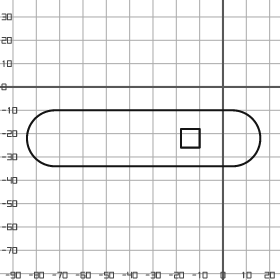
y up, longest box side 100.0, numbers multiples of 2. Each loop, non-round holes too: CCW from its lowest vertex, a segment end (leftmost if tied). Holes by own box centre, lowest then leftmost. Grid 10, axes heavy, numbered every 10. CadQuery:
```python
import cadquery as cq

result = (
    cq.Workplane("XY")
    .moveTo(-72.0, -34.0)
    .lineTo(4.0, -34.0)
    .threePointArc((16.0, -22.0), (4.0, -10.0))
    .lineTo(-72.0, -10.0)
    .threePointArc((-84.0, -22.0), (-72.0, -34.0))
    .close()
    .moveTo(-18.0, -26.0)
    .lineTo(-10.0, -26.0)
    .lineTo(-10.0, -18.0)
    .lineTo(-18.0, -18.0)
    .close()
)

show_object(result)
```